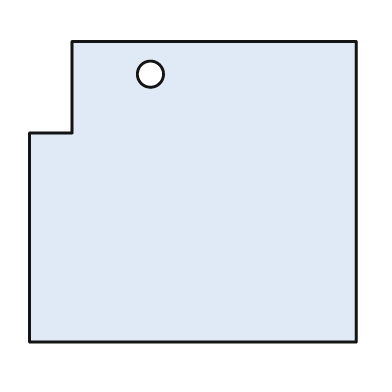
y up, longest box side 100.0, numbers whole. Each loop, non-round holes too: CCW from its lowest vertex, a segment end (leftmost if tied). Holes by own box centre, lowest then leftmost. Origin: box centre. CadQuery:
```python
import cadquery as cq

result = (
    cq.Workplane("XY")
    .moveTo(-50.0, -46.0)
    .lineTo(50.0, -46.0)
    .lineTo(50.0, 46.0)
    .lineTo(-37.0, 46.0)
    .lineTo(-37.0, 18.0)
    .lineTo(-50.0, 18.0)
    .close()
    .moveTo(-13.0, 36.0)
    .circle(4.0)
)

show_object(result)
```